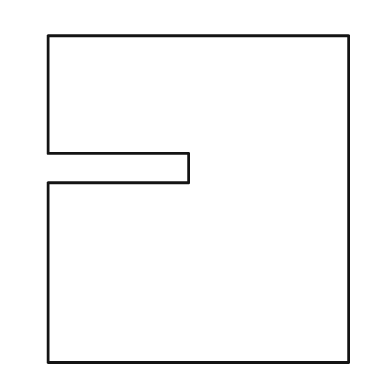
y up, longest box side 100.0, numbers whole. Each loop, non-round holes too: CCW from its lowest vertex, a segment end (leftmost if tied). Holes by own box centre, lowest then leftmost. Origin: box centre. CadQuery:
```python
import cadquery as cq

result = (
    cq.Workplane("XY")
    .moveTo(-46.0, -50.0)
    .lineTo(46.0, -50.0)
    .lineTo(46.0, 50.0)
    .lineTo(-46.0, 50.0)
    .lineTo(-46.0, 14.0)
    .lineTo(-3.0, 14.0)
    .lineTo(-3.0, 5.0)
    .lineTo(-46.0, 5.0)
    .close()
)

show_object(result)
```